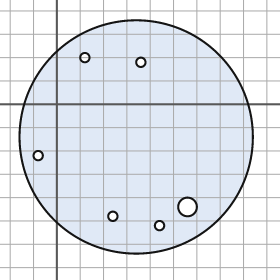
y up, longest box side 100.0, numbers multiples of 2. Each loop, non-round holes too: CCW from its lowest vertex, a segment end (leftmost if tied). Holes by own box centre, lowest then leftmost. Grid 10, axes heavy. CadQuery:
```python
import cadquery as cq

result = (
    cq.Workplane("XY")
    .moveTo(34.0, -14.0)
    .circle(50.0)
    .moveTo(44.0, -52.0)
    .circle(2.0)
    .moveTo(24.0, -48.0)
    .circle(2.0)
    .moveTo(56.0, -44.0)
    .circle(4.0)
    .moveTo(-8.0, -22.0)
    .circle(2.0)
    .moveTo(36.0, 18.0)
    .circle(2.0)
    .moveTo(12.0, 20.0)
    .circle(2.0)
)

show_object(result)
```